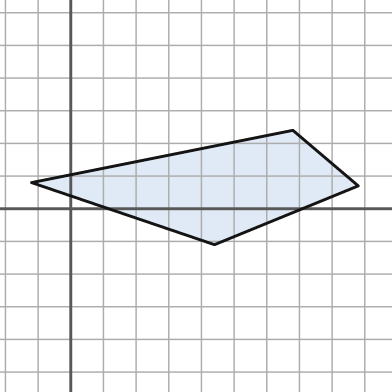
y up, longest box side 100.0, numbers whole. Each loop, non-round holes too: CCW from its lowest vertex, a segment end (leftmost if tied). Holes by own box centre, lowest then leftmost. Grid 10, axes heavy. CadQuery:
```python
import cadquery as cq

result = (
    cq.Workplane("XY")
    .moveTo(44.0, -11.0)
    .lineTo(88.0, 7.0)
    .lineTo(68.0, 24.0)
    .lineTo(-12.0, 8.0)
    .close()
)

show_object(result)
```